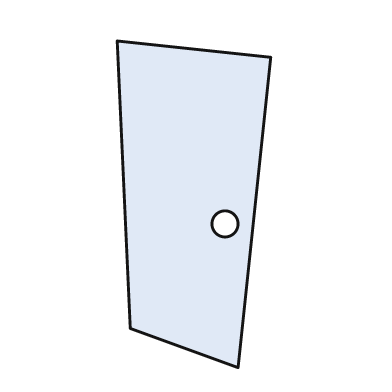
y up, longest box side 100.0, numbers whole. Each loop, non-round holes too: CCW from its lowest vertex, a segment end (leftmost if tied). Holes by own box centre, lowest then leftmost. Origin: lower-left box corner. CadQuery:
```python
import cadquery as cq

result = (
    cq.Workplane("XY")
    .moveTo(37.0, 0.0)
    .lineTo(47.0, 95.0)
    .lineTo(0.0, 100.0)
    .lineTo(4.0, 12.0)
    .close()
    .moveTo(33.0, 44.0)
    .circle(4.0)
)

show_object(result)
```